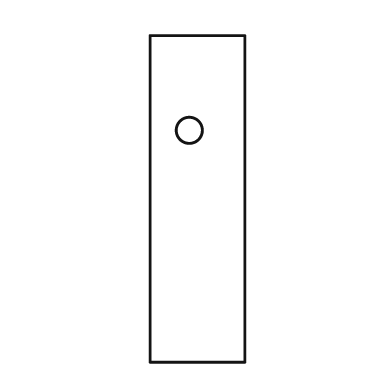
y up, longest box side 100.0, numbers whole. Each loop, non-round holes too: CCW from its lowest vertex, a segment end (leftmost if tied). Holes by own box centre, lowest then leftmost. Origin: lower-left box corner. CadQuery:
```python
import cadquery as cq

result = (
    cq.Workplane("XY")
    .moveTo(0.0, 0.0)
    .lineTo(29.0, 0.0)
    .lineTo(29.0, 100.0)
    .lineTo(0.0, 100.0)
    .close()
    .moveTo(12.0, 71.0)
    .circle(4.0)
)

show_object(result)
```